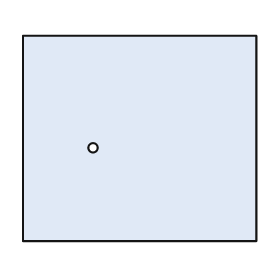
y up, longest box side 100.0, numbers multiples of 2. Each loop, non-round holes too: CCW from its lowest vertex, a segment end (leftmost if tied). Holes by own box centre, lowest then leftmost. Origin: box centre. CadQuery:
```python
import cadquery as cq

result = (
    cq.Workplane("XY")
    .moveTo(-50.0, -44.0)
    .lineTo(50.0, -44.0)
    .lineTo(50.0, 44.0)
    .lineTo(-50.0, 44.0)
    .close()
    .moveTo(-20.0, -4.0)
    .circle(2.0)
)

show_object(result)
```